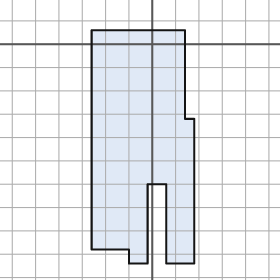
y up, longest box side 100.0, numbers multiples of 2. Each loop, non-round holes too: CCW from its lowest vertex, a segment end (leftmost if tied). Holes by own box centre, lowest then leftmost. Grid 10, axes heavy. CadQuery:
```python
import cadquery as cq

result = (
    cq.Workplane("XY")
    .moveTo(-10.0, -94.0)
    .lineTo(-2.0, -94.0)
    .lineTo(-2.0, -60.0)
    .lineTo(6.0, -60.0)
    .lineTo(6.0, -94.0)
    .lineTo(18.0, -94.0)
    .lineTo(18.0, -32.0)
    .lineTo(14.0, -32.0)
    .lineTo(14.0, 6.0)
    .lineTo(-26.0, 6.0)
    .lineTo(-26.0, -88.0)
    .lineTo(-10.0, -88.0)
    .close()
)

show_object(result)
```